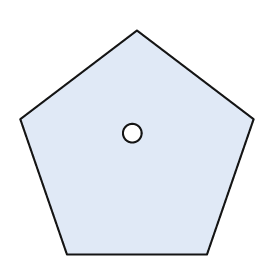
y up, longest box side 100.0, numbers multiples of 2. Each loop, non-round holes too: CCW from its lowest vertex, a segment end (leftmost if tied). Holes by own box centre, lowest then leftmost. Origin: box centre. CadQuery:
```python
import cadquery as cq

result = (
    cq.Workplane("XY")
    .moveTo(-30.0, -48.0)
    .lineTo(30.0, -48.0)
    .lineTo(50.0, 10.0)
    .lineTo(0.0, 48.0)
    .lineTo(-50.0, 10.0)
    .close()
    .moveTo(-2.0, 4.0)
    .circle(4.0)
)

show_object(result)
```